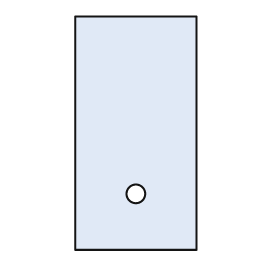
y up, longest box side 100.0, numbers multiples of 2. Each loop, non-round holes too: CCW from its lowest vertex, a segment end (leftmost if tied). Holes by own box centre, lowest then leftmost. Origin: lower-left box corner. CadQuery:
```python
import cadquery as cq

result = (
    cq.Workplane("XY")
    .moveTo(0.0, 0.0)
    .lineTo(52.0, 0.0)
    .lineTo(52.0, 100.0)
    .lineTo(0.0, 100.0)
    .close()
    .moveTo(26.0, 24.0)
    .circle(4.0)
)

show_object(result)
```